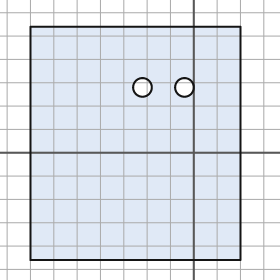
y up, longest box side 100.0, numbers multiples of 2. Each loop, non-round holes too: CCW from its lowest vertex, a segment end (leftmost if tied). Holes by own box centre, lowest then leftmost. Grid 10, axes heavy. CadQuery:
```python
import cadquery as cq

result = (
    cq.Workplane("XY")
    .moveTo(-70.0, -46.0)
    .lineTo(20.0, -46.0)
    .lineTo(20.0, 54.0)
    .lineTo(-70.0, 54.0)
    .close()
    .moveTo(-22.0, 28.0)
    .circle(4.0)
    .moveTo(-4.0, 28.0)
    .circle(4.0)
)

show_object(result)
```